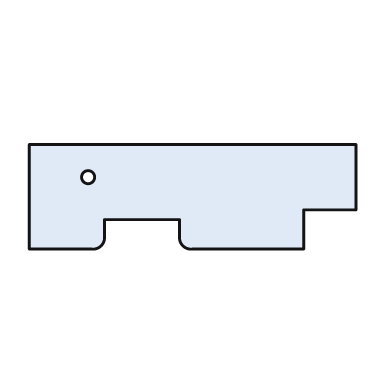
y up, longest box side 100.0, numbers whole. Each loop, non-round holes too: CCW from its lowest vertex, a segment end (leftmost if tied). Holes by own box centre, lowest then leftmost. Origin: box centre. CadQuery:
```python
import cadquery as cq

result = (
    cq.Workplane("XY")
    .moveTo(-50.0, -16.0)
    .lineTo(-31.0, -16.0)
    .threePointArc((-28.0, -15.0), (-27.0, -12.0))
    .lineTo(-27.0, -7.0)
    .lineTo(-4.0, -7.0)
    .lineTo(-4.0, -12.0)
    .threePointArc((-3.0, -15.0), (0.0, -16.0))
    .lineTo(34.0, -16.0)
    .lineTo(34.0, -4.0)
    .lineTo(50.0, -4.0)
    .lineTo(50.0, 16.0)
    .lineTo(-50.0, 16.0)
    .close()
    .moveTo(-32.0, 6.0)
    .circle(2.0)
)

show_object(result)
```